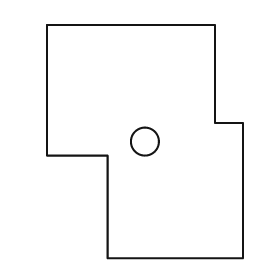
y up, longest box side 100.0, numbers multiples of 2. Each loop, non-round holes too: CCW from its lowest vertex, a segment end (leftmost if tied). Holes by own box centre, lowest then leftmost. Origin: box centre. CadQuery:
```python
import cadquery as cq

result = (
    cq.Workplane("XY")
    .moveTo(-16.0, -50.0)
    .lineTo(42.0, -50.0)
    .lineTo(42.0, 8.0)
    .lineTo(30.0, 8.0)
    .lineTo(30.0, 50.0)
    .lineTo(-42.0, 50.0)
    .lineTo(-42.0, -6.0)
    .lineTo(-16.0, -6.0)
    .close()
    .moveTo(0.0, 0.0)
    .circle(6.0)
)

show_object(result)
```